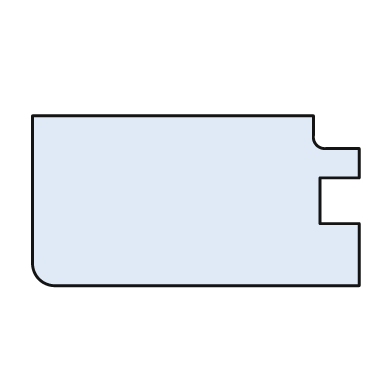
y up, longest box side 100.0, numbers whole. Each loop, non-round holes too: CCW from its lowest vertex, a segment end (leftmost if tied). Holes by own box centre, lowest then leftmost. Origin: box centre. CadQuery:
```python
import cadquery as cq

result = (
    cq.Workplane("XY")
    .moveTo(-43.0, -26.0)
    .lineTo(50.0, -26.0)
    .lineTo(50.0, -7.0)
    .lineTo(38.0, -7.0)
    .lineTo(38.0, 7.0)
    .lineTo(50.0, 7.0)
    .lineTo(50.0, 16.0)
    .lineTo(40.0, 16.0)
    .threePointArc((37.0, 17.0), (36.0, 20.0))
    .lineTo(36.0, 26.0)
    .lineTo(-50.0, 26.0)
    .lineTo(-50.0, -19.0)
    .threePointArc((-48.0, -24.0), (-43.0, -26.0))
    .close()
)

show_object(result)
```